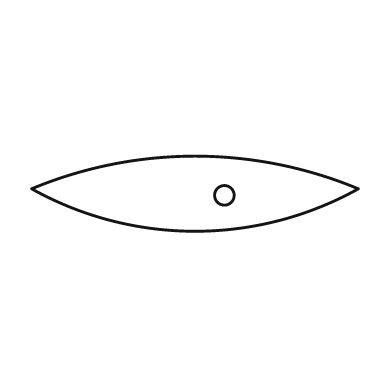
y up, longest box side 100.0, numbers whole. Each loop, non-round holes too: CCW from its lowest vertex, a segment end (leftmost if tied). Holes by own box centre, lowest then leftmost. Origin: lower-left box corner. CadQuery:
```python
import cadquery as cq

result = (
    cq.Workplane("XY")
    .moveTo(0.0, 13.0)
    .threePointArc((50.0, 0.0), (100.0, 13.0))
    .threePointArc((50.0, 23.0), (0.0, 13.0))
    .close()
    .moveTo(59.0, 11.0)
    .circle(3.0)
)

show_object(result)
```